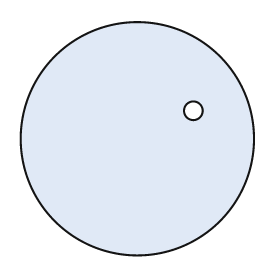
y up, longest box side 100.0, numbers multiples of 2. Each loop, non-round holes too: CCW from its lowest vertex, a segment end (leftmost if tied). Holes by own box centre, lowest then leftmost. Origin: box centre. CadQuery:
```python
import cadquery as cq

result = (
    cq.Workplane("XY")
    .moveTo(0.0, 0.0)
    .circle(50.0)
    .moveTo(24.0, 12.0)
    .circle(4.0)
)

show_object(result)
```